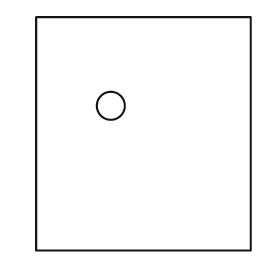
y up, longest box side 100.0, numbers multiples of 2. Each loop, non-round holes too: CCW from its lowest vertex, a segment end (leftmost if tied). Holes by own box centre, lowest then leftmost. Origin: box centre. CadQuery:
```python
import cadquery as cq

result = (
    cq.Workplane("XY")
    .moveTo(-46.0, -50.0)
    .lineTo(46.0, -50.0)
    .lineTo(46.0, 50.0)
    .lineTo(-46.0, 50.0)
    .close()
    .moveTo(-14.0, 12.0)
    .circle(6.0)
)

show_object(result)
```